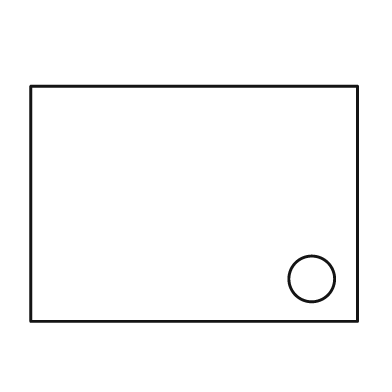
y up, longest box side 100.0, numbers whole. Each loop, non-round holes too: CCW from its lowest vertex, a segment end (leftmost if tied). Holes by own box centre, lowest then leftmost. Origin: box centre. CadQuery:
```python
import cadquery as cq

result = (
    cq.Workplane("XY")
    .moveTo(-50.0, -36.0)
    .lineTo(50.0, -36.0)
    .lineTo(50.0, 36.0)
    .lineTo(-50.0, 36.0)
    .close()
    .moveTo(36.0, -23.0)
    .circle(7.0)
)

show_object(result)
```